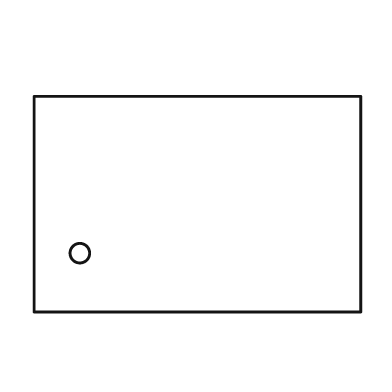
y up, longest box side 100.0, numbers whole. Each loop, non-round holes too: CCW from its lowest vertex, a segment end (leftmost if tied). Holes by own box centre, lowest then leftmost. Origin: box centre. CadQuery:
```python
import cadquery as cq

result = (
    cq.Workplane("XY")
    .moveTo(-50.0, -33.0)
    .lineTo(50.0, -33.0)
    .lineTo(50.0, 33.0)
    .lineTo(-50.0, 33.0)
    .close()
    .moveTo(-36.0, -15.0)
    .circle(3.0)
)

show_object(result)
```